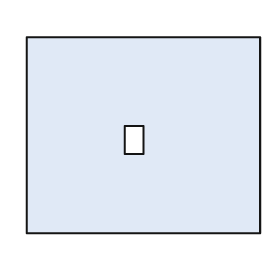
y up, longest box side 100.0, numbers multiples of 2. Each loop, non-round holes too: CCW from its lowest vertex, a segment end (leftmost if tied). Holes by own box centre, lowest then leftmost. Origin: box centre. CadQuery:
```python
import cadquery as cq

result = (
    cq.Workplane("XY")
    .moveTo(-50.0, -42.0)
    .lineTo(50.0, -42.0)
    .lineTo(50.0, 42.0)
    .lineTo(-50.0, 42.0)
    .close()
    .moveTo(-8.0, -8.0)
    .lineTo(0.0, -8.0)
    .lineTo(0.0, 4.0)
    .lineTo(-8.0, 4.0)
    .close()
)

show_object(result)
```